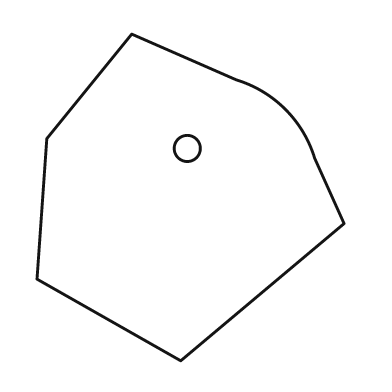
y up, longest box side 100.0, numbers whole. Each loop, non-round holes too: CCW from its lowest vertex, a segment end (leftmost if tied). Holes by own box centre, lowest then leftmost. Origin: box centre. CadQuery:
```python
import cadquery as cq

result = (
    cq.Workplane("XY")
    .moveTo(-3.0, -50.0)
    .lineTo(47.0, -8.0)
    .lineTo(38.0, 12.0)
    .threePointArc((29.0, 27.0), (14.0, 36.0))
    .lineTo(-18.0, 50.0)
    .lineTo(-44.0, 18.0)
    .lineTo(-47.0, -25.0)
    .close()
    .moveTo(-1.0, 15.0)
    .circle(4.0)
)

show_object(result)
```